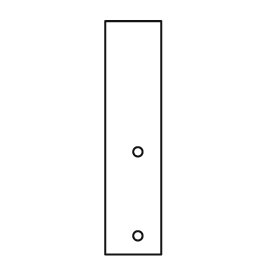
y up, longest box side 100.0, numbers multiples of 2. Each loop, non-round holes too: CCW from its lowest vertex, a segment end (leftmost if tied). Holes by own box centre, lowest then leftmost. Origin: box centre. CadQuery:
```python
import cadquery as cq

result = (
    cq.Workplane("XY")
    .moveTo(-12.0, -50.0)
    .lineTo(12.0, -50.0)
    .lineTo(12.0, 50.0)
    .lineTo(-12.0, 50.0)
    .close()
    .moveTo(2.0, -42.0)
    .circle(2.0)
    .moveTo(2.0, -6.0)
    .circle(2.0)
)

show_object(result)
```